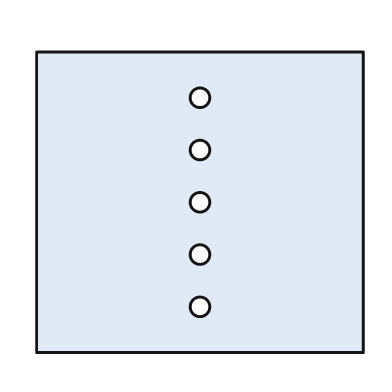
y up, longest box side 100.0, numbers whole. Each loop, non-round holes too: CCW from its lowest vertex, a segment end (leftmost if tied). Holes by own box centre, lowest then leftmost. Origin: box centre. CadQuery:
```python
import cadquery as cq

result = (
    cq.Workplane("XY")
    .moveTo(-50.0, -46.0)
    .lineTo(50.0, -46.0)
    .lineTo(50.0, 46.0)
    .lineTo(-50.0, 46.0)
    .close()
    .moveTo(0.0, -32.0)
    .circle(3.0)
    .moveTo(0.0, -16.0)
    .circle(3.0)
    .moveTo(0.0, 0.0)
    .circle(3.0)
    .moveTo(0.0, 16.0)
    .circle(3.0)
    .moveTo(0.0, 32.0)
    .circle(3.0)
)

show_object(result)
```